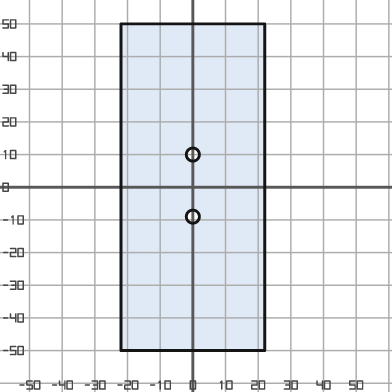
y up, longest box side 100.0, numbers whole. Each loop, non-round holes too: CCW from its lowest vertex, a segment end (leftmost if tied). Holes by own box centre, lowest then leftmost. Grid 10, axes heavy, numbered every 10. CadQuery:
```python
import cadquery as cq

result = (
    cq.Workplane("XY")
    .moveTo(-22.0, -50.0)
    .lineTo(22.0, -50.0)
    .lineTo(22.0, 50.0)
    .lineTo(-22.0, 50.0)
    .close()
    .moveTo(0.0, -9.0)
    .circle(2.0)
    .moveTo(0.0, 10.0)
    .circle(2.0)
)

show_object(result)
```